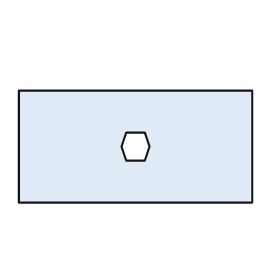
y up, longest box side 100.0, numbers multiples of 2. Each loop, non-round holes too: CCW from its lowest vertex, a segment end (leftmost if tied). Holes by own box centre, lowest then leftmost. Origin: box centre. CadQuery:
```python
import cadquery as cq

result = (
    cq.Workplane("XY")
    .moveTo(-50.0, -24.0)
    .lineTo(50.0, -24.0)
    .lineTo(50.0, 24.0)
    .lineTo(-50.0, 24.0)
    .close()
    .moveTo(-4.0, -6.0)
    .lineTo(4.0, -6.0)
    .lineTo(6.0, 0.0)
    .lineTo(4.0, 6.0)
    .lineTo(-4.0, 6.0)
    .lineTo(-6.0, 0.0)
    .close()
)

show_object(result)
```